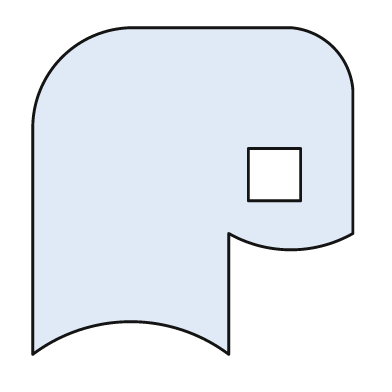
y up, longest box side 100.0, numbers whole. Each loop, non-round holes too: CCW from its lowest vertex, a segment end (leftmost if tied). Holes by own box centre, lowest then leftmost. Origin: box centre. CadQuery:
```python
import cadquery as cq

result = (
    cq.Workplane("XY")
    .moveTo(-49.0, -50.0)
    .threePointArc((-19.0, -40.0), (11.0, -50.0))
    .lineTo(11.0, -13.0)
    .threePointArc((30.0, -18.0), (49.0, -13.0))
    .lineTo(49.0, 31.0)
    .threePointArc((43.0, 44.0), (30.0, 50.0))
    .lineTo(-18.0, 50.0)
    .threePointArc((-40.0, 41.0), (-49.0, 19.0))
    .close()
    .moveTo(17.0, -3.0)
    .lineTo(33.0, -3.0)
    .lineTo(33.0, 13.0)
    .lineTo(17.0, 13.0)
    .close()
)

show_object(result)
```